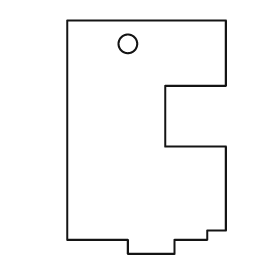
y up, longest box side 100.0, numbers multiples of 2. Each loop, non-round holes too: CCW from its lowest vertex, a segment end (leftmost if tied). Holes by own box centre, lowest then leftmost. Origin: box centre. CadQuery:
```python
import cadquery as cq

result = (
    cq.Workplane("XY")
    .moveTo(-8.0, -50.0)
    .lineTo(12.0, -50.0)
    .lineTo(12.0, -44.0)
    .lineTo(26.0, -44.0)
    .lineTo(26.0, -40.0)
    .lineTo(34.0, -40.0)
    .lineTo(34.0, -4.0)
    .lineTo(8.0, -4.0)
    .lineTo(8.0, 22.0)
    .lineTo(34.0, 22.0)
    .lineTo(34.0, 50.0)
    .lineTo(-34.0, 50.0)
    .lineTo(-34.0, -44.0)
    .lineTo(-8.0, -44.0)
    .close()
    .moveTo(-8.0, 40.0)
    .circle(4.0)
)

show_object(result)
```